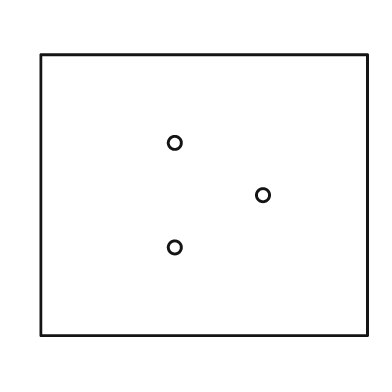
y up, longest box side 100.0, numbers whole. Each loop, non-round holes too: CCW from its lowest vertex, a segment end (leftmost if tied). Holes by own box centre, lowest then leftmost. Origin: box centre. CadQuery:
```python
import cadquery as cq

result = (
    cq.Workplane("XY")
    .moveTo(-50.0, -43.0)
    .lineTo(50.0, -43.0)
    .lineTo(50.0, 43.0)
    .lineTo(-50.0, 43.0)
    .close()
    .moveTo(-9.0, -16.0)
    .circle(2.0)
    .moveTo(18.0, 0.0)
    .circle(2.0)
    .moveTo(-9.0, 16.0)
    .circle(2.0)
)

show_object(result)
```